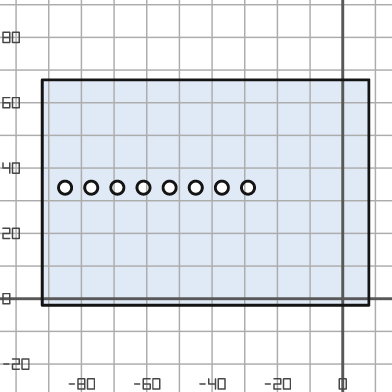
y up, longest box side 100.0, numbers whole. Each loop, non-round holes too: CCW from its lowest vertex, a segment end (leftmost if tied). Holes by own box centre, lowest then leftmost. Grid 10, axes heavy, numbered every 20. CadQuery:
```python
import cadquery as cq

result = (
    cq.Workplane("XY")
    .moveTo(-92.0, -2.0)
    .lineTo(8.0, -2.0)
    .lineTo(8.0, 67.0)
    .lineTo(-92.0, 67.0)
    .close()
    .moveTo(-85.0, 34.0)
    .circle(2.0)
    .moveTo(-77.0, 34.0)
    .circle(2.0)
    .moveTo(-69.0, 34.0)
    .circle(2.0)
    .moveTo(-61.0, 34.0)
    .circle(2.0)
    .moveTo(-53.0, 34.0)
    .circle(2.0)
    .moveTo(-45.0, 34.0)
    .circle(2.0)
    .moveTo(-37.0, 34.0)
    .circle(2.0)
    .moveTo(-29.0, 34.0)
    .circle(2.0)
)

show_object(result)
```